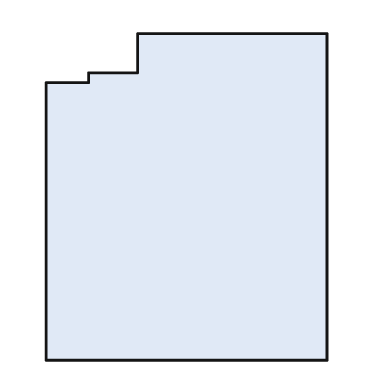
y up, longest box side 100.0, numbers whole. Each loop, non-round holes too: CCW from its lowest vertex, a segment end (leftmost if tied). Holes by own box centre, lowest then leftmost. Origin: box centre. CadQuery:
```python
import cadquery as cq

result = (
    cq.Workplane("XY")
    .moveTo(-43.0, -50.0)
    .lineTo(43.0, -50.0)
    .lineTo(43.0, 50.0)
    .lineTo(-15.0, 50.0)
    .lineTo(-15.0, 38.0)
    .lineTo(-30.0, 38.0)
    .lineTo(-30.0, 35.0)
    .lineTo(-43.0, 35.0)
    .close()
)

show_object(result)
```